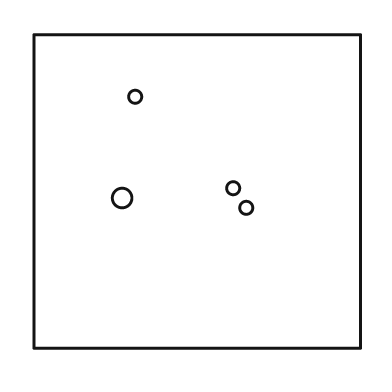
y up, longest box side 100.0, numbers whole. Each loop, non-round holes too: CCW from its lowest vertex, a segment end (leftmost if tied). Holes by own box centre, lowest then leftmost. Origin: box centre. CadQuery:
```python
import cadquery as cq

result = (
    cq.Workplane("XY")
    .moveTo(-50.0, -48.0)
    .lineTo(50.0, -48.0)
    .lineTo(50.0, 48.0)
    .lineTo(-50.0, 48.0)
    .close()
    .moveTo(15.0, -5.0)
    .circle(2.0)
    .moveTo(-23.0, -2.0)
    .circle(3.0)
    .moveTo(11.0, 1.0)
    .circle(2.0)
    .moveTo(-19.0, 29.0)
    .circle(2.0)
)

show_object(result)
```